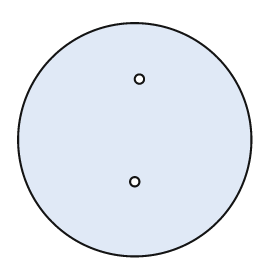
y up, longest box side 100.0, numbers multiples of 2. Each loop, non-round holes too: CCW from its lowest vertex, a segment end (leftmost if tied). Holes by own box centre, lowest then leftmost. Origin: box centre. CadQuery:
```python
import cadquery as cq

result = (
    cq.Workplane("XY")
    .moveTo(0.0, 0.0)
    .circle(50.0)
    .moveTo(0.0, -18.0)
    .circle(2.0)
    .moveTo(2.0, 26.0)
    .circle(2.0)
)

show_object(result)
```